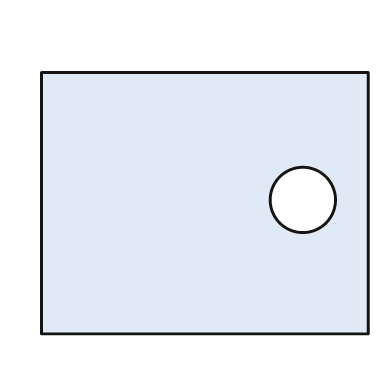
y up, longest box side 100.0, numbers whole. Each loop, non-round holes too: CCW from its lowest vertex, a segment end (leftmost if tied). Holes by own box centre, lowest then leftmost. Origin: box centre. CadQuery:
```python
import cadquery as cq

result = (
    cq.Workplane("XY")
    .moveTo(-50.0, -40.0)
    .lineTo(50.0, -40.0)
    .lineTo(50.0, 40.0)
    .lineTo(-50.0, 40.0)
    .close()
    .moveTo(30.0, 1.0)
    .circle(10.0)
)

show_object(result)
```